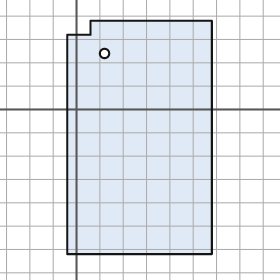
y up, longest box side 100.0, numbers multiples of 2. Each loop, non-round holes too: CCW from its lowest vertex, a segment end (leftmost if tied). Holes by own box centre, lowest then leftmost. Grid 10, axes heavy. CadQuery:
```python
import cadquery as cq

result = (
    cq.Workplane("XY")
    .moveTo(-4.0, -62.0)
    .lineTo(58.0, -62.0)
    .lineTo(58.0, 38.0)
    .lineTo(6.0, 38.0)
    .lineTo(6.0, 32.0)
    .lineTo(-4.0, 32.0)
    .close()
    .moveTo(12.0, 24.0)
    .circle(2.0)
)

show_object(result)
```